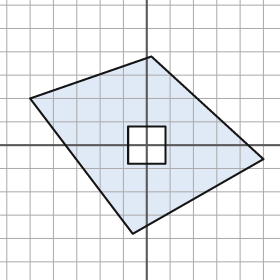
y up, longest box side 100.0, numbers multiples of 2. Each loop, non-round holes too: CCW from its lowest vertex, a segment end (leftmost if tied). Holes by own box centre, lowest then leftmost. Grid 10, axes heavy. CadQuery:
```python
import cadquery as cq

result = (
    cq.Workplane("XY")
    .moveTo(-6.0, -38.0)
    .lineTo(50.0, -6.0)
    .lineTo(2.0, 38.0)
    .lineTo(-50.0, 20.0)
    .close()
    .moveTo(-8.0, -8.0)
    .lineTo(8.0, -8.0)
    .lineTo(8.0, 8.0)
    .lineTo(-8.0, 8.0)
    .close()
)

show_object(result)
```